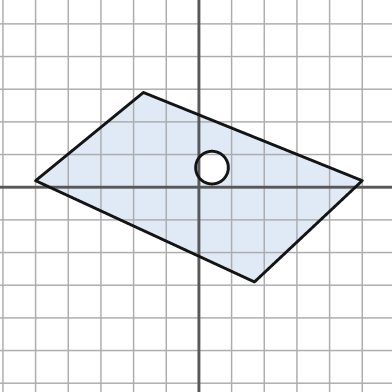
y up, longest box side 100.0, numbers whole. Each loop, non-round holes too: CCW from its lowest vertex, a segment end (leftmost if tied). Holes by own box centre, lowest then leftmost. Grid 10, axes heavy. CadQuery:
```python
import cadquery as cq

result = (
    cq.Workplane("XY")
    .moveTo(17.0, -29.0)
    .lineTo(50.0, 2.0)
    .lineTo(-17.0, 29.0)
    .lineTo(-50.0, 2.0)
    .close()
    .moveTo(4.0, 6.0)
    .circle(5.0)
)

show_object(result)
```